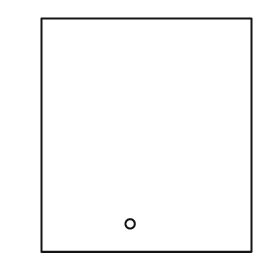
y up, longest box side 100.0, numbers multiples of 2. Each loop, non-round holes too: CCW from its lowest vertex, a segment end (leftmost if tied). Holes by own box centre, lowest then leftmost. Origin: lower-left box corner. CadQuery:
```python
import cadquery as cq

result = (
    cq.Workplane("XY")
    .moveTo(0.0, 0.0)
    .lineTo(90.0, 0.0)
    .lineTo(90.0, 100.0)
    .lineTo(0.0, 100.0)
    .close()
    .moveTo(38.0, 12.0)
    .circle(2.0)
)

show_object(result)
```